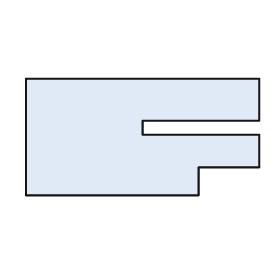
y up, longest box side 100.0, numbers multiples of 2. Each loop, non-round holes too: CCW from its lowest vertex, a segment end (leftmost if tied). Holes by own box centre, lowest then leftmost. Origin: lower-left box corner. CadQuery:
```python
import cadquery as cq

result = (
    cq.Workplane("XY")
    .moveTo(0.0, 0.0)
    .lineTo(74.0, 0.0)
    .lineTo(74.0, 12.0)
    .lineTo(100.0, 12.0)
    .lineTo(100.0, 26.0)
    .lineTo(50.0, 26.0)
    .lineTo(50.0, 32.0)
    .lineTo(100.0, 32.0)
    .lineTo(100.0, 50.0)
    .lineTo(0.0, 50.0)
    .close()
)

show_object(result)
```